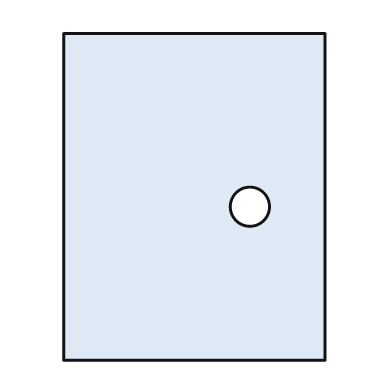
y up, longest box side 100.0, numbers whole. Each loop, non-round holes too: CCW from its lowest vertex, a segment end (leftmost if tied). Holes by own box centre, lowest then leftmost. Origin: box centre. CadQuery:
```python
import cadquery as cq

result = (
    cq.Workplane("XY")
    .moveTo(-40.0, -50.0)
    .lineTo(40.0, -50.0)
    .lineTo(40.0, 50.0)
    .lineTo(-40.0, 50.0)
    .close()
    .moveTo(17.0, -3.0)
    .circle(6.0)
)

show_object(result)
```